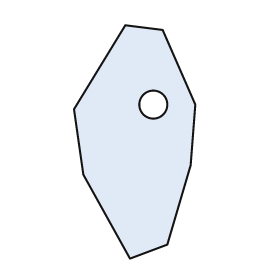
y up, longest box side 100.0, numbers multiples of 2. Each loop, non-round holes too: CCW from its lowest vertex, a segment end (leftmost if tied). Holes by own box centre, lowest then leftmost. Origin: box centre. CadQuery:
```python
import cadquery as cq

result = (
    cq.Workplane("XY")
    .moveTo(-2.0, -50.0)
    .lineTo(14.0, -44.0)
    .lineTo(24.0, -10.0)
    .lineTo(26.0, 16.0)
    .lineTo(12.0, 48.0)
    .lineTo(-4.0, 50.0)
    .lineTo(-26.0, 14.0)
    .lineTo(-22.0, -14.0)
    .close()
    .moveTo(8.0, 16.0)
    .circle(6.0)
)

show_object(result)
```